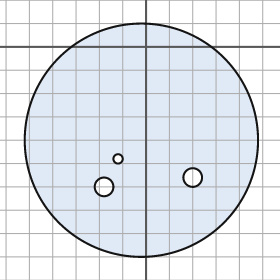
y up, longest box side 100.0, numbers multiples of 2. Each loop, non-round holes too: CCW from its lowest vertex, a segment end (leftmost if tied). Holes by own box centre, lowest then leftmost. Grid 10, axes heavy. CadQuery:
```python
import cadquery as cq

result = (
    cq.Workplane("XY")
    .moveTo(-2.0, -40.0)
    .circle(50.0)
    .moveTo(-18.0, -60.0)
    .circle(4.0)
    .moveTo(20.0, -56.0)
    .circle(4.0)
    .moveTo(-12.0, -48.0)
    .circle(2.0)
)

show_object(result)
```